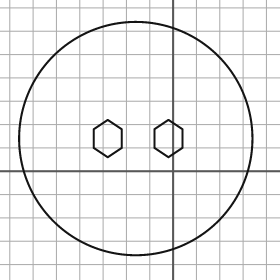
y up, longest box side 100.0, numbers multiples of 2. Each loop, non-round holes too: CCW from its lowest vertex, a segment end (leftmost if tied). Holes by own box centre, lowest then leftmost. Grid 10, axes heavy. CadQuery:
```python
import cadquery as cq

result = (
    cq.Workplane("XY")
    .moveTo(-16.0, 14.0)
    .circle(50.0)
    .moveTo(-28.0, 6.0)
    .lineTo(-22.0, 10.0)
    .lineTo(-22.0, 18.0)
    .lineTo(-28.0, 22.0)
    .lineTo(-34.0, 18.0)
    .lineTo(-34.0, 10.0)
    .close()
    .moveTo(-2.0, 6.0)
    .lineTo(4.0, 10.0)
    .lineTo(4.0, 18.0)
    .lineTo(-2.0, 22.0)
    .lineTo(-8.0, 18.0)
    .lineTo(-8.0, 10.0)
    .close()
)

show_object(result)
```